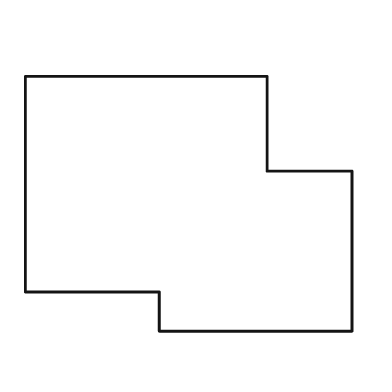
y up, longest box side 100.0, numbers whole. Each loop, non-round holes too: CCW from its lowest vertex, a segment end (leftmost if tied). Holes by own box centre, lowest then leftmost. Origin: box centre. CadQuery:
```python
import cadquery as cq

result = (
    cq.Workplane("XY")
    .moveTo(-9.0, -39.0)
    .lineTo(50.0, -39.0)
    .lineTo(50.0, 10.0)
    .lineTo(24.0, 10.0)
    .lineTo(24.0, 39.0)
    .lineTo(-50.0, 39.0)
    .lineTo(-50.0, -27.0)
    .lineTo(-9.0, -27.0)
    .close()
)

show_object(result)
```